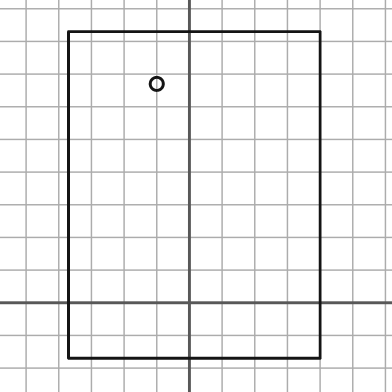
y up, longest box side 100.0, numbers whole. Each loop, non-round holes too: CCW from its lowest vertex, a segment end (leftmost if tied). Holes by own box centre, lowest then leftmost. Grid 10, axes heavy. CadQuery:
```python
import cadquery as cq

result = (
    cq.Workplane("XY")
    .moveTo(-37.0, -17.0)
    .lineTo(40.0, -17.0)
    .lineTo(40.0, 83.0)
    .lineTo(-37.0, 83.0)
    .close()
    .moveTo(-10.0, 67.0)
    .circle(2.0)
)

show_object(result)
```